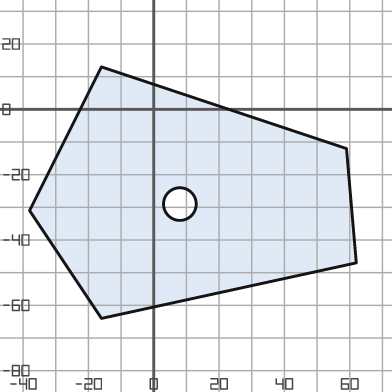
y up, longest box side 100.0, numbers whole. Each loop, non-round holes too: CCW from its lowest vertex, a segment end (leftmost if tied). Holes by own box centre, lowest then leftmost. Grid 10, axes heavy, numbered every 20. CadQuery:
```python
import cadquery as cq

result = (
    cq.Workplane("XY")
    .moveTo(-16.0, -64.0)
    .lineTo(62.0, -47.0)
    .lineTo(59.0, -12.0)
    .lineTo(-16.0, 13.0)
    .lineTo(-38.0, -31.0)
    .close()
    .moveTo(8.0, -29.0)
    .circle(5.0)
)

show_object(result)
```